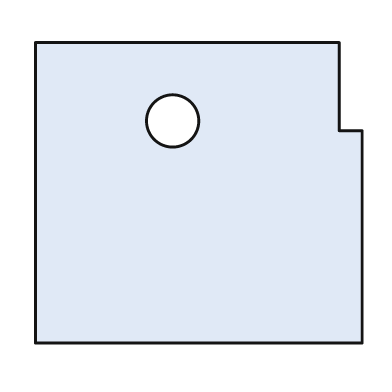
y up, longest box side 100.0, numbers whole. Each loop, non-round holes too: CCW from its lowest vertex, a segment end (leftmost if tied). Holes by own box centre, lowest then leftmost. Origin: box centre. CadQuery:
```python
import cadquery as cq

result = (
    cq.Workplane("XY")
    .moveTo(-50.0, -46.0)
    .lineTo(50.0, -46.0)
    .lineTo(50.0, 19.0)
    .lineTo(43.0, 19.0)
    .lineTo(43.0, 46.0)
    .lineTo(-50.0, 46.0)
    .close()
    .moveTo(-8.0, 22.0)
    .circle(8.0)
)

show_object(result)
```